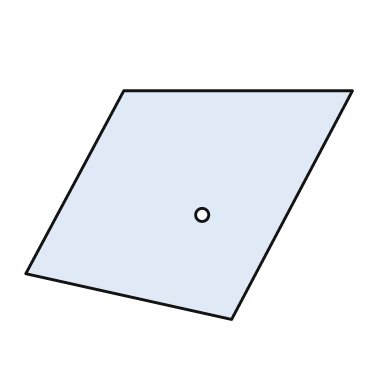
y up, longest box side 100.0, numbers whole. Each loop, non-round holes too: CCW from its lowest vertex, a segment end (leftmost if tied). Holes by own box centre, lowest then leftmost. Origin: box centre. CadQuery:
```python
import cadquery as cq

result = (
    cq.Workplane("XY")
    .moveTo(13.0, -35.0)
    .lineTo(50.0, 35.0)
    .lineTo(-20.0, 35.0)
    .lineTo(-50.0, -21.0)
    .close()
    .moveTo(4.0, -3.0)
    .circle(2.0)
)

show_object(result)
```